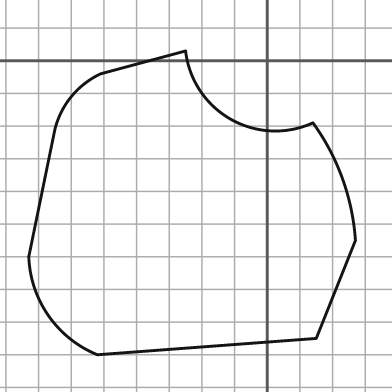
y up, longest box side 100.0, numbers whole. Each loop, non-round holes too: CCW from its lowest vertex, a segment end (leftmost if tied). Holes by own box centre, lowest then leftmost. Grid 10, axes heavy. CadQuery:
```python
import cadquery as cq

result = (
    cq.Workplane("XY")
    .moveTo(-52.0, -90.0)
    .lineTo(15.0, -85.0)
    .lineTo(27.0, -55.0)
    .threePointArc((23.0, -36.0), (14.0, -19.0))
    .threePointArc((-11.0, -18.0), (-25.0, 3.0))
    .lineTo(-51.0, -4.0)
    .threePointArc((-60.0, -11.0), (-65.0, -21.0))
    .lineTo(-73.0, -60.0)
    .threePointArc((-67.0, -78.0), (-52.0, -90.0))
    .close()
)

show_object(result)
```